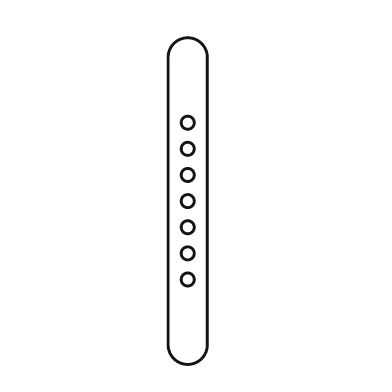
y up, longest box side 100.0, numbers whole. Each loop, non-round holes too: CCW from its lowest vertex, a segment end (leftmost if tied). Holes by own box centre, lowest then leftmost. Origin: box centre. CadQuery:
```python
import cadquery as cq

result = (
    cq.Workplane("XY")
    .moveTo(-6.0, -44.0)
    .threePointArc((0.0, -50.0), (6.0, -44.0))
    .lineTo(6.0, 44.0)
    .threePointArc((0.0, 50.0), (-6.0, 44.0))
    .close()
    .moveTo(0.0, -24.0)
    .circle(2.0)
    .moveTo(0.0, -16.0)
    .circle(2.0)
    .moveTo(0.0, -8.0)
    .circle(2.0)
    .moveTo(0.0, 0.0)
    .circle(2.0)
    .moveTo(0.0, 8.0)
    .circle(2.0)
    .moveTo(0.0, 16.0)
    .circle(2.0)
    .moveTo(0.0, 24.0)
    .circle(2.0)
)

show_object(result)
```